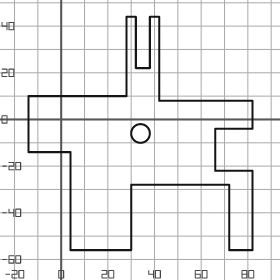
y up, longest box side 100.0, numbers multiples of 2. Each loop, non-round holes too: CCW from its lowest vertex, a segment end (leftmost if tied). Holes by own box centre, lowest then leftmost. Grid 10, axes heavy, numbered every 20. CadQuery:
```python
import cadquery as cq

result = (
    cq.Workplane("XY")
    .moveTo(4.0, -56.0)
    .lineTo(30.0, -56.0)
    .lineTo(30.0, -28.0)
    .lineTo(72.0, -28.0)
    .lineTo(72.0, -56.0)
    .lineTo(82.0, -56.0)
    .lineTo(82.0, -22.0)
    .lineTo(66.0, -22.0)
    .lineTo(66.0, -4.0)
    .lineTo(82.0, -4.0)
    .lineTo(82.0, 8.0)
    .lineTo(42.0, 8.0)
    .lineTo(42.0, 44.0)
    .lineTo(38.0, 44.0)
    .lineTo(38.0, 22.0)
    .lineTo(32.0, 22.0)
    .lineTo(32.0, 44.0)
    .lineTo(28.0, 44.0)
    .lineTo(28.0, 10.0)
    .lineTo(-14.0, 10.0)
    .lineTo(-14.0, -14.0)
    .lineTo(4.0, -14.0)
    .close()
    .moveTo(34.0, -6.0)
    .circle(4.0)
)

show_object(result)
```